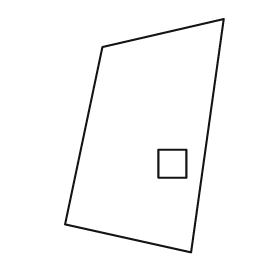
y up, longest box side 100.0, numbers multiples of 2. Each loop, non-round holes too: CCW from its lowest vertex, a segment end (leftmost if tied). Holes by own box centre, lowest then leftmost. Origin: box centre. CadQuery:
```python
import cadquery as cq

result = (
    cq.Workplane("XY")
    .moveTo(20.0, -50.0)
    .lineTo(34.0, 50.0)
    .lineTo(-18.0, 38.0)
    .lineTo(-34.0, -38.0)
    .close()
    .moveTo(6.0, -18.0)
    .lineTo(18.0, -18.0)
    .lineTo(18.0, -6.0)
    .lineTo(6.0, -6.0)
    .close()
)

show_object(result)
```